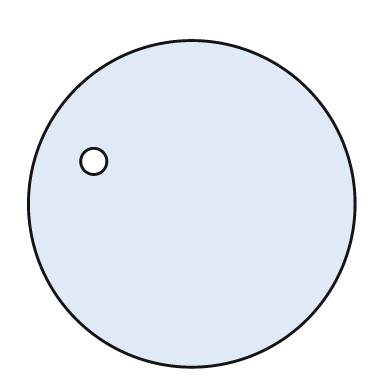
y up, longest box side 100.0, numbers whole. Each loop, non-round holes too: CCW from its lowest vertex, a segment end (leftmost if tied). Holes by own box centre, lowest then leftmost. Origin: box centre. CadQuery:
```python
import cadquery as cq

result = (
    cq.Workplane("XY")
    .moveTo(0.0, 0.0)
    .circle(50.0)
    .moveTo(-30.0, 13.0)
    .circle(4.0)
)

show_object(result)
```